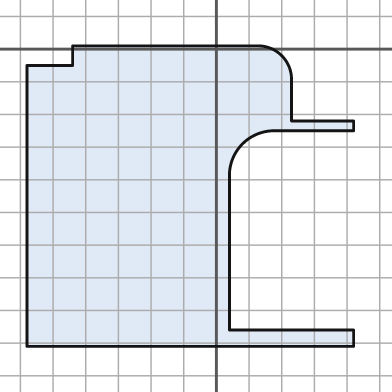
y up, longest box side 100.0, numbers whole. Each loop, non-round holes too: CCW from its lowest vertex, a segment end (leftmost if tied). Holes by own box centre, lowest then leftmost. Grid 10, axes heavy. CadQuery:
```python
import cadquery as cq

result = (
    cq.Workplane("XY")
    .moveTo(-58.0, -91.0)
    .lineTo(42.0, -91.0)
    .lineTo(42.0, -86.0)
    .lineTo(4.0, -86.0)
    .lineTo(4.0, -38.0)
    .threePointArc((8.0, -29.0), (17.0, -25.0))
    .lineTo(42.0, -25.0)
    .lineTo(42.0, -22.0)
    .lineTo(23.0, -22.0)
    .lineTo(23.0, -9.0)
    .threePointArc((20.0, -2.0), (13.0, 1.0))
    .lineTo(-44.0, 1.0)
    .lineTo(-44.0, -5.0)
    .lineTo(-58.0, -5.0)
    .close()
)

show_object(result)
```